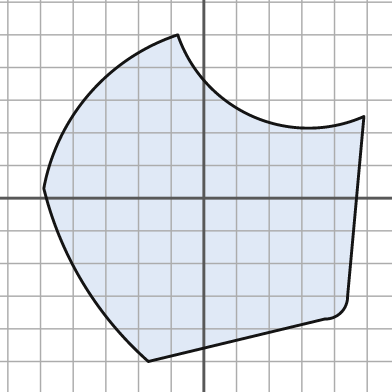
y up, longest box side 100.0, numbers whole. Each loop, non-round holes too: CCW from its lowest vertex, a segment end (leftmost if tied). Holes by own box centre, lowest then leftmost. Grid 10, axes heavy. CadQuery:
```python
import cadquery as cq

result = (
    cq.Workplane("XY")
    .moveTo(-17.0, -50.0)
    .lineTo(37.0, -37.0)
    .threePointArc((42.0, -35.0), (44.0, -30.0))
    .lineTo(49.0, 25.0)
    .threePointArc((15.0, 25.0), (-8.0, 50.0))
    .threePointArc((-35.0, 32.0), (-49.0, 3.0))
    .threePointArc((-37.0, -26.0), (-17.0, -50.0))
    .close()
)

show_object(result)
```